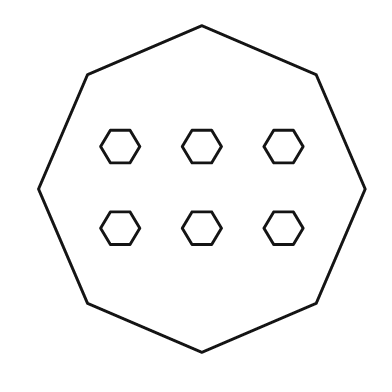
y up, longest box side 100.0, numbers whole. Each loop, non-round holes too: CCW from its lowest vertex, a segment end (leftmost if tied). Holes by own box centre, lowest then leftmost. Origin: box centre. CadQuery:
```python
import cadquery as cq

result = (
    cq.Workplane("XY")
    .moveTo(0.0, -50.0)
    .lineTo(35.0, -35.0)
    .lineTo(50.0, 0.0)
    .lineTo(35.0, 35.0)
    .lineTo(0.0, 50.0)
    .lineTo(-35.0, 35.0)
    .lineTo(-50.0, 0.0)
    .lineTo(-35.0, -35.0)
    .close()
    .moveTo(-28.0, -17.0)
    .lineTo(-22.0, -17.0)
    .lineTo(-19.0, -12.0)
    .lineTo(-22.0, -7.0)
    .lineTo(-28.0, -7.0)
    .lineTo(-31.0, -12.0)
    .close()
    .moveTo(-3.0, -17.0)
    .lineTo(3.0, -17.0)
    .lineTo(6.0, -12.0)
    .lineTo(3.0, -7.0)
    .lineTo(-3.0, -7.0)
    .lineTo(-6.0, -12.0)
    .close()
    .moveTo(22.0, -17.0)
    .lineTo(28.0, -17.0)
    .lineTo(31.0, -12.0)
    .lineTo(28.0, -7.0)
    .lineTo(22.0, -7.0)
    .lineTo(19.0, -12.0)
    .close()
    .moveTo(-28.0, 8.0)
    .lineTo(-22.0, 8.0)
    .lineTo(-19.0, 13.0)
    .lineTo(-22.0, 18.0)
    .lineTo(-28.0, 18.0)
    .lineTo(-31.0, 13.0)
    .close()
    .moveTo(-3.0, 8.0)
    .lineTo(3.0, 8.0)
    .lineTo(6.0, 13.0)
    .lineTo(3.0, 18.0)
    .lineTo(-3.0, 18.0)
    .lineTo(-6.0, 13.0)
    .close()
    .moveTo(22.0, 8.0)
    .lineTo(28.0, 8.0)
    .lineTo(31.0, 13.0)
    .lineTo(28.0, 18.0)
    .lineTo(22.0, 18.0)
    .lineTo(19.0, 13.0)
    .close()
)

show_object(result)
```